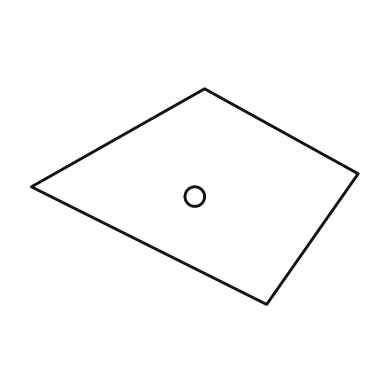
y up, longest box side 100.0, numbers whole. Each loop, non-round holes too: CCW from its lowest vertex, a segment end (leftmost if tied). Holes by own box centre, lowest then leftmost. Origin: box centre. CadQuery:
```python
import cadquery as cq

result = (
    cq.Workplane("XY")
    .moveTo(22.0, -33.0)
    .lineTo(50.0, 7.0)
    .lineTo(3.0, 33.0)
    .lineTo(-50.0, 3.0)
    .close()
    .moveTo(0.0, 0.0)
    .circle(3.0)
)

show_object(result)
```